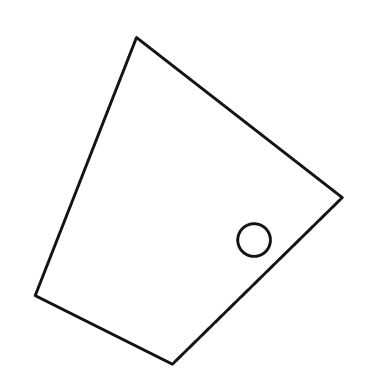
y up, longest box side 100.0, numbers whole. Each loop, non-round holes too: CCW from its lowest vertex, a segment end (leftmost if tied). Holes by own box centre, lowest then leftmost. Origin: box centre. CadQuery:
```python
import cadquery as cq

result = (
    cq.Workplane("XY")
    .moveTo(-5.0, -50.0)
    .lineTo(47.0, 1.0)
    .lineTo(-16.0, 50.0)
    .lineTo(-47.0, -29.0)
    .close()
    .moveTo(20.0, -12.0)
    .circle(5.0)
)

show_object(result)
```